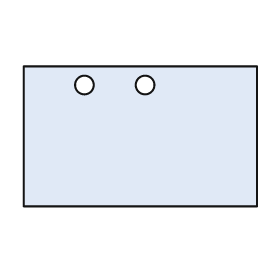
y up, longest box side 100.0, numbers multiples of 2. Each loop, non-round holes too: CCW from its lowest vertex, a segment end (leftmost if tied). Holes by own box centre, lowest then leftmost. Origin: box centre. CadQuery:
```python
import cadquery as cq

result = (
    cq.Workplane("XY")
    .moveTo(-50.0, -30.0)
    .lineTo(50.0, -30.0)
    .lineTo(50.0, 30.0)
    .lineTo(-50.0, 30.0)
    .close()
    .moveTo(-24.0, 22.0)
    .circle(4.0)
    .moveTo(2.0, 22.0)
    .circle(4.0)
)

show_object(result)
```